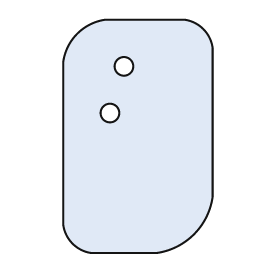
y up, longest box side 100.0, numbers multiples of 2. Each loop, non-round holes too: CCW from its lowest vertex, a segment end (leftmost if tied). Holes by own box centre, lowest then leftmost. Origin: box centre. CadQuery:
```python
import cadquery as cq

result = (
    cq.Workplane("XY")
    .moveTo(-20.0, -50.0)
    .lineTo(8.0, -50.0)
    .threePointArc((24.0, -42.0), (32.0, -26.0))
    .lineTo(32.0, 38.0)
    .threePointArc((28.0, 46.0), (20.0, 50.0))
    .lineTo(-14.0, 50.0)
    .threePointArc((-26.0, 44.0), (-32.0, 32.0))
    .lineTo(-32.0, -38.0)
    .threePointArc((-28.0, -46.0), (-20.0, -50.0))
    .close()
    .moveTo(-12.0, 10.0)
    .circle(4.0)
    .moveTo(-6.0, 30.0)
    .circle(4.0)
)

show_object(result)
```